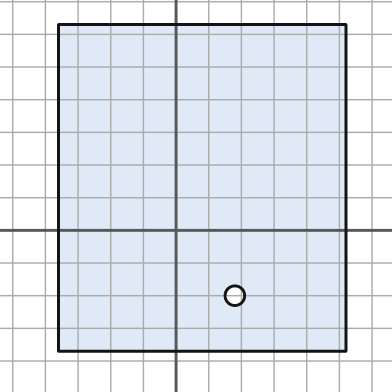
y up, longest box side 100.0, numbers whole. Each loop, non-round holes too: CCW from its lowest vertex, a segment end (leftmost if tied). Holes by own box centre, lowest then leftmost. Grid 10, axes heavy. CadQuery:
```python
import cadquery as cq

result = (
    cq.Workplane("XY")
    .moveTo(-36.0, -37.0)
    .lineTo(52.0, -37.0)
    .lineTo(52.0, 63.0)
    .lineTo(-36.0, 63.0)
    .close()
    .moveTo(18.0, -20.0)
    .circle(3.0)
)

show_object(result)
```